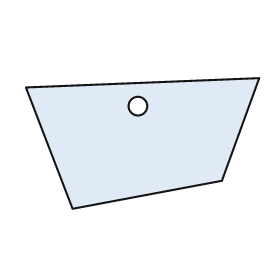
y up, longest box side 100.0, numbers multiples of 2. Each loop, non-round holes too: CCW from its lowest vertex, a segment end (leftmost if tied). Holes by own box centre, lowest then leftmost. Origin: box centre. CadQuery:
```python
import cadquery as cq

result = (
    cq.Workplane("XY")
    .moveTo(-30.0, -28.0)
    .lineTo(34.0, -16.0)
    .lineTo(50.0, 28.0)
    .lineTo(-50.0, 24.0)
    .close()
    .moveTo(-2.0, 16.0)
    .circle(4.0)
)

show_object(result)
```